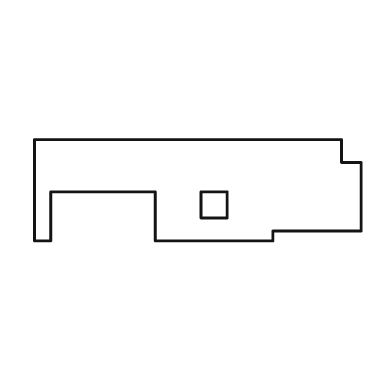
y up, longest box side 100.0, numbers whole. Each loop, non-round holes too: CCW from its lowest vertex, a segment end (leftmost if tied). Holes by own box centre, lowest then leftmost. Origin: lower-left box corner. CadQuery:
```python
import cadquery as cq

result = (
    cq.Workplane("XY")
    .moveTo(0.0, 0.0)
    .lineTo(5.0, 0.0)
    .lineTo(5.0, 15.0)
    .lineTo(37.0, 15.0)
    .lineTo(37.0, 0.0)
    .lineTo(73.0, 0.0)
    .lineTo(73.0, 3.0)
    .lineTo(100.0, 3.0)
    .lineTo(100.0, 24.0)
    .lineTo(94.0, 24.0)
    .lineTo(94.0, 31.0)
    .lineTo(0.0, 31.0)
    .close()
    .moveTo(51.0, 7.0)
    .lineTo(59.0, 7.0)
    .lineTo(59.0, 15.0)
    .lineTo(51.0, 15.0)
    .close()
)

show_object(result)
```